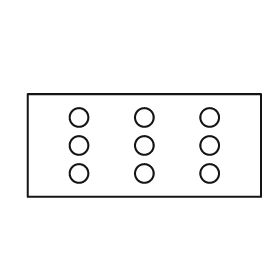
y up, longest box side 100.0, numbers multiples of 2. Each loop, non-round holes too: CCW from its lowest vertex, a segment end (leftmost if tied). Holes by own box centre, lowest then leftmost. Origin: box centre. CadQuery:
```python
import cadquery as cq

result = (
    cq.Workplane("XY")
    .moveTo(-50.0, -22.0)
    .lineTo(50.0, -22.0)
    .lineTo(50.0, 22.0)
    .lineTo(-50.0, 22.0)
    .close()
    .moveTo(-28.0, -12.0)
    .circle(4.0)
    .moveTo(0.0, -12.0)
    .circle(4.0)
    .moveTo(28.0, -12.0)
    .circle(4.0)
    .moveTo(-28.0, 0.0)
    .circle(4.0)
    .moveTo(0.0, 0.0)
    .circle(4.0)
    .moveTo(28.0, 0.0)
    .circle(4.0)
    .moveTo(-28.0, 12.0)
    .circle(4.0)
    .moveTo(0.0, 12.0)
    .circle(4.0)
    .moveTo(28.0, 12.0)
    .circle(4.0)
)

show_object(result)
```